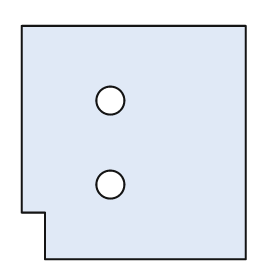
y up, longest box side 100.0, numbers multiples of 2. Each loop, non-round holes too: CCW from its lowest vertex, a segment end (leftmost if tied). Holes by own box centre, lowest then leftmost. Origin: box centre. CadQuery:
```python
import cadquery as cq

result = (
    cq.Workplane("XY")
    .moveTo(-38.0, -50.0)
    .lineTo(48.0, -50.0)
    .lineTo(48.0, 50.0)
    .lineTo(-48.0, 50.0)
    .lineTo(-48.0, -30.0)
    .lineTo(-38.0, -30.0)
    .close()
    .moveTo(-10.0, -18.0)
    .circle(6.0)
    .moveTo(-10.0, 18.0)
    .circle(6.0)
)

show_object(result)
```